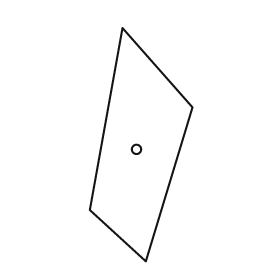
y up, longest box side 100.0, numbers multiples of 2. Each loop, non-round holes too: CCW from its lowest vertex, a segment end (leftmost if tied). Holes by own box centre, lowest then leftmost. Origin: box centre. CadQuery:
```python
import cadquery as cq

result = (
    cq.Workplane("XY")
    .moveTo(2.0, -50.0)
    .lineTo(22.0, 16.0)
    .lineTo(-8.0, 50.0)
    .lineTo(-22.0, -28.0)
    .close()
    .moveTo(-2.0, -2.0)
    .circle(2.0)
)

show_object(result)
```